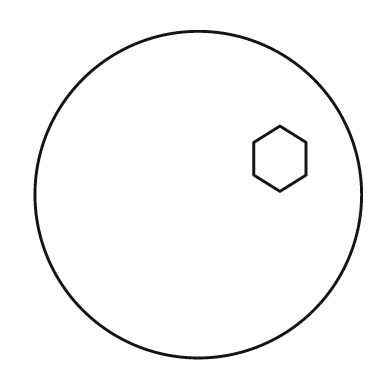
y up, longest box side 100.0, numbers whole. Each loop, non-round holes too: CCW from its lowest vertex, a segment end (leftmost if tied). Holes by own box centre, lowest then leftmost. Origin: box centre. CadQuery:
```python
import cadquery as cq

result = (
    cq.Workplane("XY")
    .moveTo(0.0, 0.0)
    .circle(50.0)
    .moveTo(25.0, 1.0)
    .lineTo(33.0, 6.0)
    .lineTo(33.0, 16.0)
    .lineTo(25.0, 21.0)
    .lineTo(17.0, 16.0)
    .lineTo(17.0, 6.0)
    .close()
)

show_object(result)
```